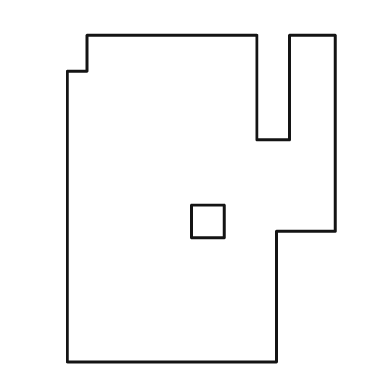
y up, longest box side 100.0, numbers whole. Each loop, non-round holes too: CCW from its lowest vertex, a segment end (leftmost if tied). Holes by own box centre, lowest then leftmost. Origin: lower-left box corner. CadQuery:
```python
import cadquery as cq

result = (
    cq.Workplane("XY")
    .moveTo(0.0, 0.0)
    .lineTo(64.0, 0.0)
    .lineTo(64.0, 40.0)
    .lineTo(82.0, 40.0)
    .lineTo(82.0, 100.0)
    .lineTo(68.0, 100.0)
    .lineTo(68.0, 68.0)
    .lineTo(58.0, 68.0)
    .lineTo(58.0, 100.0)
    .lineTo(6.0, 100.0)
    .lineTo(6.0, 89.0)
    .lineTo(0.0, 89.0)
    .close()
    .moveTo(38.0, 38.0)
    .lineTo(48.0, 38.0)
    .lineTo(48.0, 48.0)
    .lineTo(38.0, 48.0)
    .close()
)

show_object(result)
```